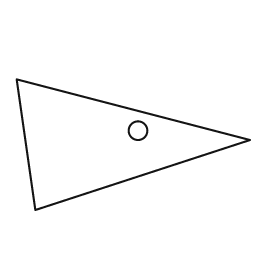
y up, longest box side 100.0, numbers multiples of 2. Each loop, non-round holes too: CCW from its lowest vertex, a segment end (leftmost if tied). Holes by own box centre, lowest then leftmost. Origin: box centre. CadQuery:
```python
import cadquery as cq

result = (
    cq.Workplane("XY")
    .moveTo(-42.0, -28.0)
    .lineTo(50.0, 2.0)
    .lineTo(-50.0, 28.0)
    .close()
    .moveTo(2.0, 6.0)
    .circle(4.0)
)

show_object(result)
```